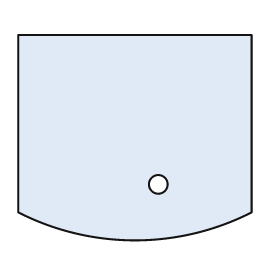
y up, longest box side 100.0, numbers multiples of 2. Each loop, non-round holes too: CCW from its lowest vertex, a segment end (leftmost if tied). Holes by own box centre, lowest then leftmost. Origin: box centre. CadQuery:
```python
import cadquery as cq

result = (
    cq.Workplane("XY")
    .moveTo(-50.0, -32.0)
    .threePointArc((0.0, -44.0), (50.0, -32.0))
    .lineTo(50.0, 44.0)
    .lineTo(-50.0, 44.0)
    .close()
    .moveTo(10.0, -20.0)
    .circle(4.0)
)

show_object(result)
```